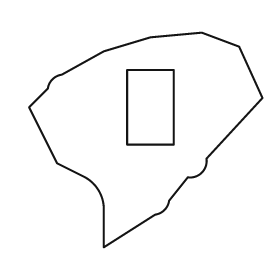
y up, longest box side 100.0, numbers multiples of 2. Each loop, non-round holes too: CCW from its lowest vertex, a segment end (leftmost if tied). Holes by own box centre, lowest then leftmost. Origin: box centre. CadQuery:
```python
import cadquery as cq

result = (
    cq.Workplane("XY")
    .moveTo(-18.0, -46.0)
    .lineTo(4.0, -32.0)
    .threePointArc((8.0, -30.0), (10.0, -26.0))
    .lineTo(18.0, -16.0)
    .threePointArc((24.0, -14.0), (26.0, -8.0))
    .lineTo(50.0, 18.0)
    .lineTo(40.0, 40.0)
    .lineTo(24.0, 46.0)
    .lineTo(2.0, 44.0)
    .lineTo(-18.0, 38.0)
    .lineTo(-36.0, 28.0)
    .threePointArc((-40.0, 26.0), (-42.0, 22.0))
    .lineTo(-50.0, 14.0)
    .lineTo(-38.0, -10.0)
    .lineTo(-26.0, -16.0)
    .threePointArc((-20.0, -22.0), (-18.0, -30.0))
    .close()
    .moveTo(-8.0, -2.0)
    .lineTo(12.0, -2.0)
    .lineTo(12.0, 30.0)
    .lineTo(-8.0, 30.0)
    .close()
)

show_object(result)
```